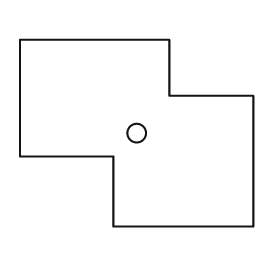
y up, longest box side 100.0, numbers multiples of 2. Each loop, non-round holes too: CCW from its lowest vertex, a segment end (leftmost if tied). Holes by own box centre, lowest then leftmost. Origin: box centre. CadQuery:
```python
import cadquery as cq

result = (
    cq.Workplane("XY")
    .moveTo(-10.0, -40.0)
    .lineTo(50.0, -40.0)
    .lineTo(50.0, 16.0)
    .lineTo(14.0, 16.0)
    .lineTo(14.0, 40.0)
    .lineTo(-50.0, 40.0)
    .lineTo(-50.0, -10.0)
    .lineTo(-10.0, -10.0)
    .close()
    .moveTo(0.0, 0.0)
    .circle(4.0)
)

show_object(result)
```